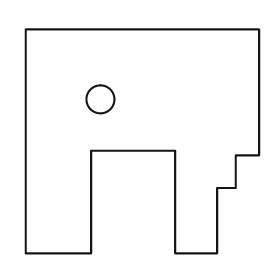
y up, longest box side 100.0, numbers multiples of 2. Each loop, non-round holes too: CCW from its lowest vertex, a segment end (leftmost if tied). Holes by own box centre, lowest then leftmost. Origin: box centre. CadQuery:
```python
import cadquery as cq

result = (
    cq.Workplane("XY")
    .moveTo(-50.0, -48.0)
    .lineTo(-22.0, -48.0)
    .lineTo(-22.0, -4.0)
    .lineTo(14.0, -4.0)
    .lineTo(14.0, -48.0)
    .lineTo(32.0, -48.0)
    .lineTo(32.0, -20.0)
    .lineTo(40.0, -20.0)
    .lineTo(40.0, -6.0)
    .lineTo(50.0, -6.0)
    .lineTo(50.0, 48.0)
    .lineTo(-50.0, 48.0)
    .close()
    .moveTo(-18.0, 18.0)
    .circle(6.0)
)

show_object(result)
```